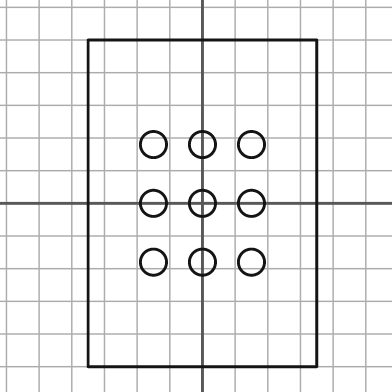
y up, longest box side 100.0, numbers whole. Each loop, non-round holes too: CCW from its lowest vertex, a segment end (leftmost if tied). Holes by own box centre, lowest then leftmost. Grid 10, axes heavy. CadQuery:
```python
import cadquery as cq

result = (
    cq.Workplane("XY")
    .moveTo(-35.0, -50.0)
    .lineTo(35.0, -50.0)
    .lineTo(35.0, 50.0)
    .lineTo(-35.0, 50.0)
    .close()
    .moveTo(-15.0, -18.0)
    .circle(4.0)
    .moveTo(0.0, -18.0)
    .circle(4.0)
    .moveTo(15.0, -18.0)
    .circle(4.0)
    .moveTo(-15.0, 0.0)
    .circle(4.0)
    .moveTo(0.0, 0.0)
    .circle(4.0)
    .moveTo(15.0, 0.0)
    .circle(4.0)
    .moveTo(-15.0, 18.0)
    .circle(4.0)
    .moveTo(0.0, 18.0)
    .circle(4.0)
    .moveTo(15.0, 18.0)
    .circle(4.0)
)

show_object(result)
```